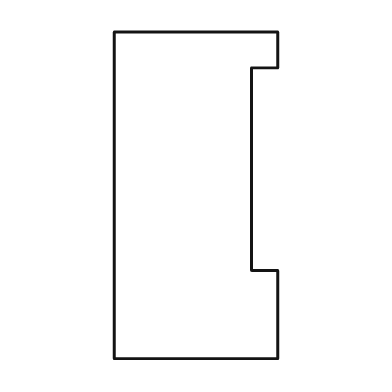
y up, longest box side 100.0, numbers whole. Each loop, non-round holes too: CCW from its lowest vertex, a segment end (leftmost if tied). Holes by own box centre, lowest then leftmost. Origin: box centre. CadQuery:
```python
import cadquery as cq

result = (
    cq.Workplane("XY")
    .moveTo(-25.0, -50.0)
    .lineTo(25.0, -50.0)
    .lineTo(25.0, -23.0)
    .lineTo(17.0, -23.0)
    .lineTo(17.0, 39.0)
    .lineTo(25.0, 39.0)
    .lineTo(25.0, 50.0)
    .lineTo(-25.0, 50.0)
    .close()
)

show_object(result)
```